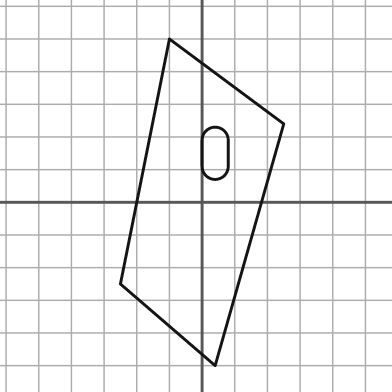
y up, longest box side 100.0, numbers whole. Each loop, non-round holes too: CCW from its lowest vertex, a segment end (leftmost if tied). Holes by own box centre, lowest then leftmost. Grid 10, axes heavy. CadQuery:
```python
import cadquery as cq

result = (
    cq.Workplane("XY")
    .moveTo(4.0, -50.0)
    .lineTo(25.0, 24.0)
    .lineTo(-10.0, 50.0)
    .lineTo(-25.0, -25.0)
    .close()
    .moveTo(0.0, 11.0)
    .threePointArc((4.0, 7.0), (8.0, 11.0))
    .lineTo(8.0, 19.0)
    .threePointArc((4.0, 23.0), (0.0, 19.0))
    .close()
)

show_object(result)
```